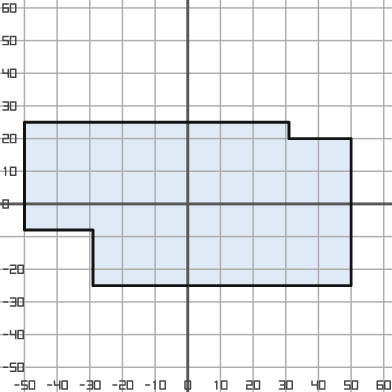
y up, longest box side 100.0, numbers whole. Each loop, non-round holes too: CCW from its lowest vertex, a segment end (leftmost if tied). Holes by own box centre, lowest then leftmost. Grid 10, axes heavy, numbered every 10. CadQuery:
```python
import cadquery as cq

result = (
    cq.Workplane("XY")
    .moveTo(-29.0, -25.0)
    .lineTo(50.0, -25.0)
    .lineTo(50.0, 20.0)
    .lineTo(31.0, 20.0)
    .lineTo(31.0, 25.0)
    .lineTo(-50.0, 25.0)
    .lineTo(-50.0, -8.0)
    .lineTo(-29.0, -8.0)
    .close()
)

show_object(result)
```